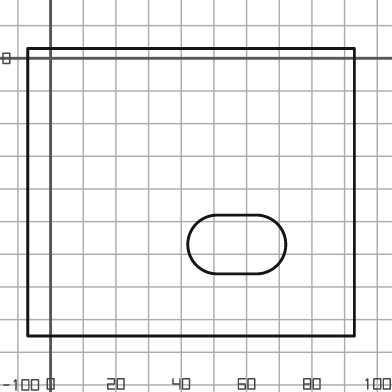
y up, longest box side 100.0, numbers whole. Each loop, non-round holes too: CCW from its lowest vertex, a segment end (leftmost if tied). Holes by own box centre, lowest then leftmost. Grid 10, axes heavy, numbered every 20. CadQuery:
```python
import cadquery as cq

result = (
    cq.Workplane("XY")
    .moveTo(-7.0, -85.0)
    .lineTo(93.0, -85.0)
    .lineTo(93.0, 3.0)
    .lineTo(-7.0, 3.0)
    .close()
    .moveTo(51.0, -66.0)
    .lineTo(63.0, -66.0)
    .threePointArc((72.0, -57.0), (63.0, -48.0))
    .lineTo(51.0, -48.0)
    .threePointArc((42.0, -57.0), (51.0, -66.0))
    .close()
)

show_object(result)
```